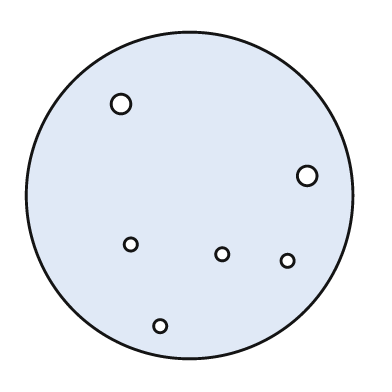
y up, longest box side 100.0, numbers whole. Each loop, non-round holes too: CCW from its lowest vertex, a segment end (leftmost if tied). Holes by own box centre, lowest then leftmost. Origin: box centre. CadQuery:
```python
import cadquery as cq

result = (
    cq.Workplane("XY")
    .moveTo(0.0, 0.0)
    .circle(50.0)
    .moveTo(-9.0, -40.0)
    .circle(2.0)
    .moveTo(30.0, -20.0)
    .circle(2.0)
    .moveTo(10.0, -18.0)
    .circle(2.0)
    .moveTo(-18.0, -15.0)
    .circle(2.0)
    .moveTo(36.0, 6.0)
    .circle(3.0)
    .moveTo(-21.0, 28.0)
    .circle(3.0)
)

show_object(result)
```